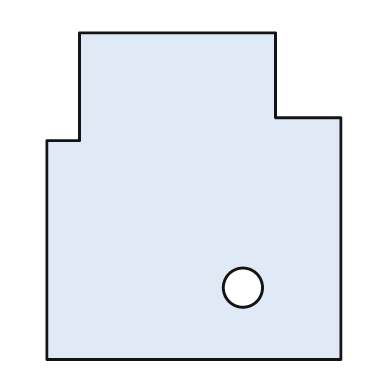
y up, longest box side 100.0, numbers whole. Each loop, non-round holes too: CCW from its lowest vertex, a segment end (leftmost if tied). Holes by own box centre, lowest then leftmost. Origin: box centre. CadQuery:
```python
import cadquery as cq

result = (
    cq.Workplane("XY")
    .moveTo(-45.0, -50.0)
    .lineTo(45.0, -50.0)
    .lineTo(45.0, 24.0)
    .lineTo(25.0, 24.0)
    .lineTo(25.0, 50.0)
    .lineTo(-35.0, 50.0)
    .lineTo(-35.0, 17.0)
    .lineTo(-45.0, 17.0)
    .close()
    .moveTo(15.0, -28.0)
    .circle(6.0)
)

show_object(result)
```